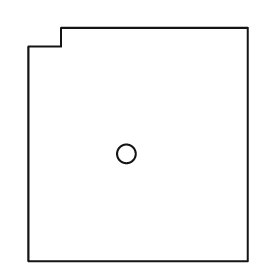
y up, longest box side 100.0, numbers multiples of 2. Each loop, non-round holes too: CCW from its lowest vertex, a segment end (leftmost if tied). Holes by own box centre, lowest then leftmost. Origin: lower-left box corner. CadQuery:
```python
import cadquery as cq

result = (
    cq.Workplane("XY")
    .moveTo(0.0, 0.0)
    .lineTo(94.0, 0.0)
    .lineTo(94.0, 100.0)
    .lineTo(14.0, 100.0)
    .lineTo(14.0, 92.0)
    .lineTo(0.0, 92.0)
    .close()
    .moveTo(42.0, 46.0)
    .circle(4.0)
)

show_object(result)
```